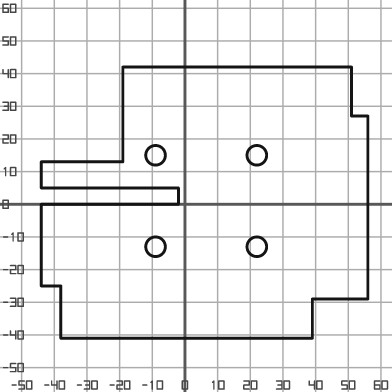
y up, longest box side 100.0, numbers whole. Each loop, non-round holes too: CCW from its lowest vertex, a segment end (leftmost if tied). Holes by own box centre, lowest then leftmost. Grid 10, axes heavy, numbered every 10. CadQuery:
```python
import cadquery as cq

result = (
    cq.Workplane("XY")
    .moveTo(-38.0, -41.0)
    .lineTo(39.0, -41.0)
    .lineTo(39.0, -29.0)
    .lineTo(56.0, -29.0)
    .lineTo(56.0, 27.0)
    .lineTo(51.0, 27.0)
    .lineTo(51.0, 42.0)
    .lineTo(-19.0, 42.0)
    .lineTo(-19.0, 13.0)
    .lineTo(-44.0, 13.0)
    .lineTo(-44.0, 5.0)
    .lineTo(-2.0, 5.0)
    .lineTo(-2.0, 0.0)
    .lineTo(-44.0, 0.0)
    .lineTo(-44.0, -25.0)
    .lineTo(-38.0, -25.0)
    .close()
    .moveTo(-9.0, -13.0)
    .circle(3.0)
    .moveTo(22.0, -13.0)
    .circle(3.0)
    .moveTo(-9.0, 15.0)
    .circle(3.0)
    .moveTo(22.0, 15.0)
    .circle(3.0)
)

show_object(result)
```